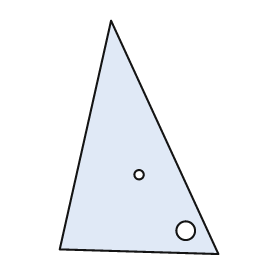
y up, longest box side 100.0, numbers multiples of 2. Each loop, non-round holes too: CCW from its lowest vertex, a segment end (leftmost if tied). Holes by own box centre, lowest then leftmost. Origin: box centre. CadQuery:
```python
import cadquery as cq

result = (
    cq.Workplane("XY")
    .moveTo(34.0, -50.0)
    .lineTo(-12.0, 50.0)
    .lineTo(-34.0, -48.0)
    .close()
    .moveTo(20.0, -40.0)
    .circle(4.0)
    .moveTo(0.0, -16.0)
    .circle(2.0)
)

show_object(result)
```